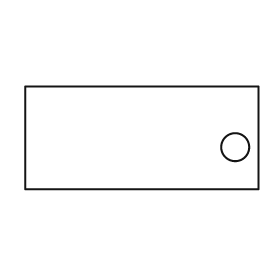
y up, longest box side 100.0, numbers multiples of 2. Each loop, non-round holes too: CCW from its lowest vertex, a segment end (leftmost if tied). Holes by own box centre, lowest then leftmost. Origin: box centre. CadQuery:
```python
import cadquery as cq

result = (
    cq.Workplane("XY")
    .moveTo(-50.0, -22.0)
    .lineTo(50.0, -22.0)
    .lineTo(50.0, 22.0)
    .lineTo(-50.0, 22.0)
    .close()
    .moveTo(40.0, -4.0)
    .circle(6.0)
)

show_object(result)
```